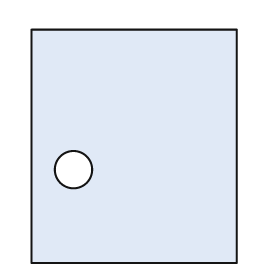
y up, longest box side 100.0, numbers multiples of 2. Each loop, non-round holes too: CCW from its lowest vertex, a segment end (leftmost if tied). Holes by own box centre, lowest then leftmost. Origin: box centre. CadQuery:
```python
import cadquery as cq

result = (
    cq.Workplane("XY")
    .moveTo(-44.0, -50.0)
    .lineTo(44.0, -50.0)
    .lineTo(44.0, 50.0)
    .lineTo(-44.0, 50.0)
    .close()
    .moveTo(-26.0, -10.0)
    .circle(8.0)
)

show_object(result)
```